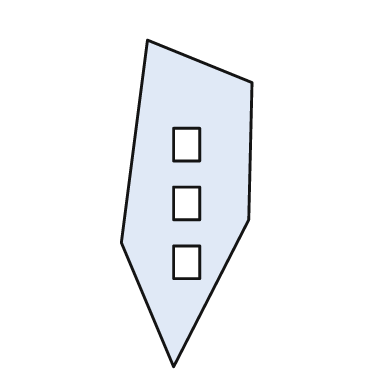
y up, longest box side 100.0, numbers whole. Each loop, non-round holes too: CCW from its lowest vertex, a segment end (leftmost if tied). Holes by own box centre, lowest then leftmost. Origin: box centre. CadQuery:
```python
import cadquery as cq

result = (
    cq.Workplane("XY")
    .moveTo(-4.0, -50.0)
    .lineTo(19.0, -5.0)
    .lineTo(20.0, 37.0)
    .lineTo(-12.0, 50.0)
    .lineTo(-20.0, -12.0)
    .close()
    .moveTo(-4.0, -23.0)
    .lineTo(4.0, -23.0)
    .lineTo(4.0, -13.0)
    .lineTo(-4.0, -13.0)
    .close()
    .moveTo(-4.0, -5.0)
    .lineTo(4.0, -5.0)
    .lineTo(4.0, 5.0)
    .lineTo(-4.0, 5.0)
    .close()
    .moveTo(-4.0, 13.0)
    .lineTo(4.0, 13.0)
    .lineTo(4.0, 23.0)
    .lineTo(-4.0, 23.0)
    .close()
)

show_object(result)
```